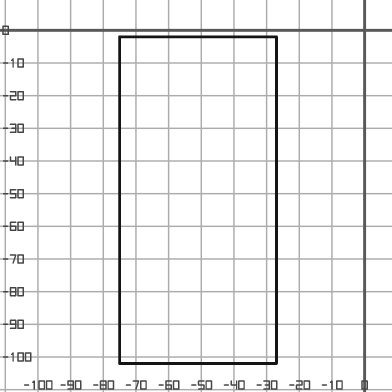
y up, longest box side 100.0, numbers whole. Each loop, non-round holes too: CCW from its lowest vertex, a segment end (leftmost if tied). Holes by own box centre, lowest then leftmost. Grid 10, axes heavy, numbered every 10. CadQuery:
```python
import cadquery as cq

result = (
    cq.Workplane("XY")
    .moveTo(-75.0, -102.0)
    .lineTo(-27.0, -102.0)
    .lineTo(-27.0, -2.0)
    .lineTo(-75.0, -2.0)
    .close()
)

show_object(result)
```